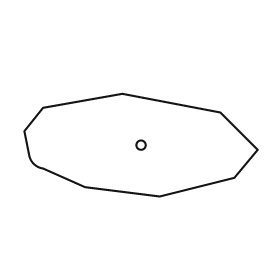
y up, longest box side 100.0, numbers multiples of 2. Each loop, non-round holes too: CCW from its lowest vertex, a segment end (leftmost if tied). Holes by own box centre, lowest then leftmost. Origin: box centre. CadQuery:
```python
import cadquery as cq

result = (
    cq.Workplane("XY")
    .moveTo(8.0, -22.0)
    .lineTo(40.0, -14.0)
    .lineTo(50.0, -2.0)
    .lineTo(34.0, 14.0)
    .lineTo(-8.0, 22.0)
    .lineTo(-42.0, 16.0)
    .lineTo(-50.0, 6.0)
    .lineTo(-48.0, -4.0)
    .threePointArc((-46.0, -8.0), (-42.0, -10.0))
    .lineTo(-24.0, -18.0)
    .close()
    .moveTo(0.0, 0.0)
    .circle(2.0)
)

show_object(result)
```